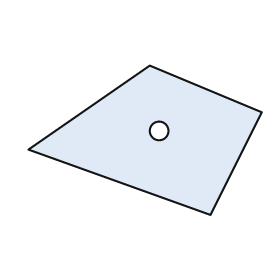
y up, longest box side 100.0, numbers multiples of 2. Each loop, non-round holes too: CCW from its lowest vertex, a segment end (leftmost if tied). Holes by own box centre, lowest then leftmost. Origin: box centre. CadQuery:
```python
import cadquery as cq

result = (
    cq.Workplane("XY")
    .moveTo(28.0, -32.0)
    .lineTo(50.0, 12.0)
    .lineTo(2.0, 32.0)
    .lineTo(-50.0, -4.0)
    .close()
    .moveTo(6.0, 4.0)
    .circle(4.0)
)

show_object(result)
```